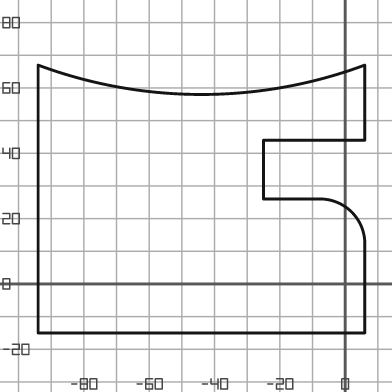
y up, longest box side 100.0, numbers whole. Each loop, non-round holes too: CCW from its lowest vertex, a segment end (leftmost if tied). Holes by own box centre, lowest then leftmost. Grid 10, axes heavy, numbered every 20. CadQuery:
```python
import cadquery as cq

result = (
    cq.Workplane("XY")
    .moveTo(-94.0, -15.0)
    .lineTo(6.0, -15.0)
    .lineTo(6.0, 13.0)
    .threePointArc((2.0, 22.0), (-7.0, 26.0))
    .lineTo(-25.0, 26.0)
    .lineTo(-25.0, 44.0)
    .lineTo(6.0, 44.0)
    .lineTo(6.0, 67.0)
    .threePointArc((-44.0, 58.0), (-94.0, 67.0))
    .close()
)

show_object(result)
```